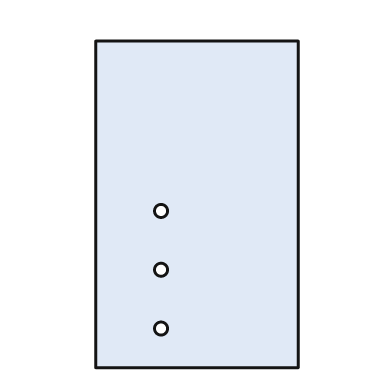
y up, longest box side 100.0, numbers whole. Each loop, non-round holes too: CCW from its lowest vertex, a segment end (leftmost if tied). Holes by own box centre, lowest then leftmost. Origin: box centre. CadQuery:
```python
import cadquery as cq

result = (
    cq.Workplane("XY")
    .moveTo(-31.0, -50.0)
    .lineTo(31.0, -50.0)
    .lineTo(31.0, 50.0)
    .lineTo(-31.0, 50.0)
    .close()
    .moveTo(-11.0, -38.0)
    .circle(2.0)
    .moveTo(-11.0, -20.0)
    .circle(2.0)
    .moveTo(-11.0, -2.0)
    .circle(2.0)
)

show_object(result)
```